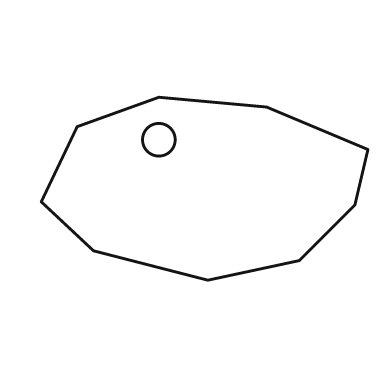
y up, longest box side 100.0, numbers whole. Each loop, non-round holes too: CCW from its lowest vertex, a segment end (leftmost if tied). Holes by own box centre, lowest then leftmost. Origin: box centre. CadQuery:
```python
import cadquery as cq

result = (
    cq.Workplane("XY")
    .moveTo(1.0, -28.0)
    .lineTo(29.0, -22.0)
    .lineTo(46.0, -5.0)
    .lineTo(50.0, 12.0)
    .lineTo(19.0, 25.0)
    .lineTo(-14.0, 28.0)
    .lineTo(-39.0, 19.0)
    .lineTo(-50.0, -4.0)
    .lineTo(-34.0, -19.0)
    .close()
    .moveTo(-14.0, 15.0)
    .circle(5.0)
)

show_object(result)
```